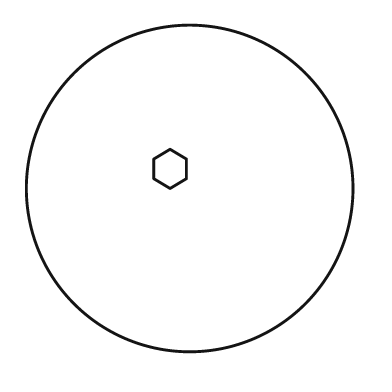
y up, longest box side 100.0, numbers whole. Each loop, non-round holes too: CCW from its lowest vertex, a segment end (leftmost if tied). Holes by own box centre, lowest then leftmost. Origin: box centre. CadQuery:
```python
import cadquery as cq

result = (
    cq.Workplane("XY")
    .moveTo(0.0, 0.0)
    .circle(50.0)
    .moveTo(-6.0, 0.0)
    .lineTo(-1.0, 3.0)
    .lineTo(-1.0, 9.0)
    .lineTo(-6.0, 12.0)
    .lineTo(-11.0, 9.0)
    .lineTo(-11.0, 3.0)
    .close()
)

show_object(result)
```